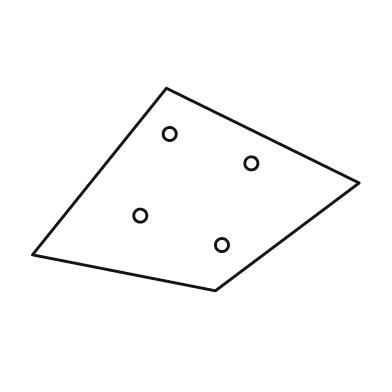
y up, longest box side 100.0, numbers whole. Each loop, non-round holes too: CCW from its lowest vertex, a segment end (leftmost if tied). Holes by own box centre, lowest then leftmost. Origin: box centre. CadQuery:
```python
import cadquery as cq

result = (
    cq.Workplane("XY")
    .moveTo(6.0, -31.0)
    .lineTo(50.0, 2.0)
    .lineTo(-9.0, 31.0)
    .lineTo(-50.0, -20.0)
    .close()
    .moveTo(8.0, -17.0)
    .circle(2.0)
    .moveTo(-17.0, -8.0)
    .circle(2.0)
    .moveTo(17.0, 8.0)
    .circle(2.0)
    .moveTo(-8.0, 17.0)
    .circle(2.0)
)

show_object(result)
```